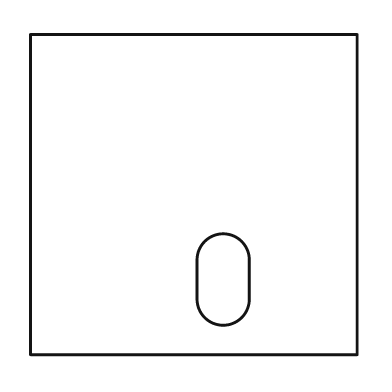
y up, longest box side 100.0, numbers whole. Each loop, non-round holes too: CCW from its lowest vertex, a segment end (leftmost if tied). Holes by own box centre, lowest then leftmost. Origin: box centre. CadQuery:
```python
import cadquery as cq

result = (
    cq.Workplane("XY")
    .moveTo(-50.0, -49.0)
    .lineTo(50.0, -49.0)
    .lineTo(50.0, 49.0)
    .lineTo(-50.0, 49.0)
    .close()
    .moveTo(1.0, -32.0)
    .threePointArc((9.0, -40.0), (17.0, -32.0))
    .lineTo(17.0, -20.0)
    .threePointArc((9.0, -12.0), (1.0, -20.0))
    .close()
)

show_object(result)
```